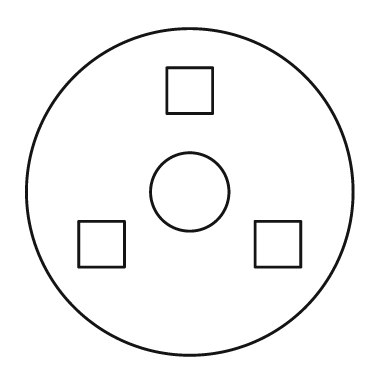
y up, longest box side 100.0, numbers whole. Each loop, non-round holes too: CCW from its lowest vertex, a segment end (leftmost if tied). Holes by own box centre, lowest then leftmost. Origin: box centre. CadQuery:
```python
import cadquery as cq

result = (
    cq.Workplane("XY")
    .moveTo(0.0, 0.0)
    .circle(50.0)
    .moveTo(-34.0, -23.0)
    .lineTo(-20.0, -23.0)
    .lineTo(-20.0, -9.0)
    .lineTo(-34.0, -9.0)
    .close()
    .moveTo(20.0, -23.0)
    .lineTo(34.0, -23.0)
    .lineTo(34.0, -9.0)
    .lineTo(20.0, -9.0)
    .close()
    .moveTo(0.0, 0.0)
    .circle(12.0)
    .moveTo(-7.0, 24.0)
    .lineTo(7.0, 24.0)
    .lineTo(7.0, 38.0)
    .lineTo(-7.0, 38.0)
    .close()
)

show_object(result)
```